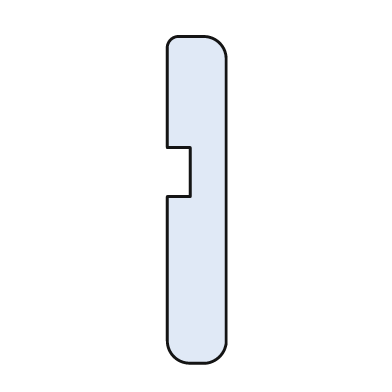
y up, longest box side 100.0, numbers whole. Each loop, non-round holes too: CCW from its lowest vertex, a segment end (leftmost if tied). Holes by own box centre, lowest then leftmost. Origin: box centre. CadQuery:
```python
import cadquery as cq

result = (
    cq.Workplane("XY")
    .moveTo(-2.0, -50.0)
    .lineTo(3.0, -50.0)
    .threePointArc((7.0, -48.0), (9.0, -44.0))
    .lineTo(9.0, 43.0)
    .threePointArc((7.0, 48.0), (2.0, 50.0))
    .lineTo(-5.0, 50.0)
    .threePointArc((-8.0, 49.0), (-9.0, 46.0))
    .lineTo(-9.0, 16.0)
    .lineTo(-2.0, 16.0)
    .lineTo(-2.0, 1.0)
    .lineTo(-9.0, 1.0)
    .lineTo(-9.0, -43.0)
    .threePointArc((-7.0, -48.0), (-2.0, -50.0))
    .close()
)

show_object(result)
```